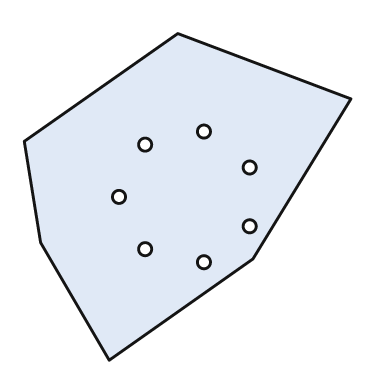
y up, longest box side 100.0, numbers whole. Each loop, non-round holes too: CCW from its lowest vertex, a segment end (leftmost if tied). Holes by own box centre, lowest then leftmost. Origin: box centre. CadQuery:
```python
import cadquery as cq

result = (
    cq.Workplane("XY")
    .moveTo(-24.0, -50.0)
    .lineTo(20.0, -19.0)
    .lineTo(50.0, 30.0)
    .lineTo(-3.0, 50.0)
    .lineTo(-50.0, 17.0)
    .lineTo(-45.0, -14.0)
    .close()
    .moveTo(5.0, -20.0)
    .circle(2.0)
    .moveTo(-13.0, -16.0)
    .circle(2.0)
    .moveTo(19.0, -9.0)
    .circle(2.0)
    .moveTo(-21.0, 0.0)
    .circle(2.0)
    .moveTo(19.0, 9.0)
    .circle(2.0)
    .moveTo(-13.0, 16.0)
    .circle(2.0)
    .moveTo(5.0, 20.0)
    .circle(2.0)
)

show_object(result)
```